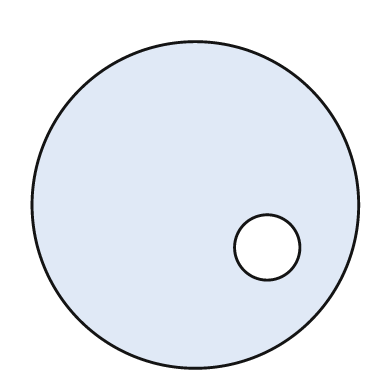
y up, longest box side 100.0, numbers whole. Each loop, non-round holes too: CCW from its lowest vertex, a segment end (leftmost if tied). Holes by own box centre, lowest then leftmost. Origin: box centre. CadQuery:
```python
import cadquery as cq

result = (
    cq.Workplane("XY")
    .moveTo(0.0, 0.0)
    .circle(50.0)
    .moveTo(22.0, -13.0)
    .circle(10.0)
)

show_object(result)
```